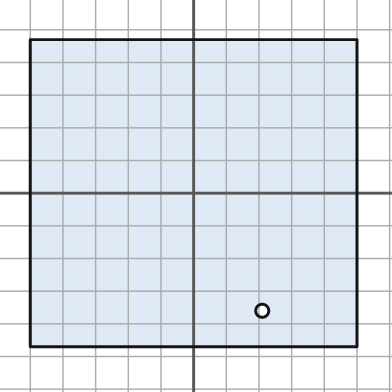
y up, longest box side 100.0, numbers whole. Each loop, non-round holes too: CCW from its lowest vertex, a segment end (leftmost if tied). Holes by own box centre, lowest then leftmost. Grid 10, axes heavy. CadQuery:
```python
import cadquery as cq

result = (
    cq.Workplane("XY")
    .moveTo(-50.0, -47.0)
    .lineTo(50.0, -47.0)
    .lineTo(50.0, 47.0)
    .lineTo(-50.0, 47.0)
    .close()
    .moveTo(21.0, -36.0)
    .circle(2.0)
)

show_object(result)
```